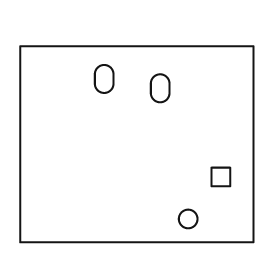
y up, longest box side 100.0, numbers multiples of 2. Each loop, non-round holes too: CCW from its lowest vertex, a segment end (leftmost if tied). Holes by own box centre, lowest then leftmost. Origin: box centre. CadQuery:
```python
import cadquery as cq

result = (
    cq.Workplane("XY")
    .moveTo(-50.0, -42.0)
    .lineTo(50.0, -42.0)
    .lineTo(50.0, 42.0)
    .lineTo(-50.0, 42.0)
    .close()
    .moveTo(22.0, -32.0)
    .circle(4.0)
    .moveTo(32.0, -18.0)
    .lineTo(40.0, -18.0)
    .lineTo(40.0, -10.0)
    .lineTo(32.0, -10.0)
    .close()
    .moveTo(6.0, 22.0)
    .threePointArc((10.0, 18.0), (14.0, 22.0))
    .lineTo(14.0, 26.0)
    .threePointArc((10.0, 30.0), (6.0, 26.0))
    .close()
    .moveTo(-18.0, 26.0)
    .threePointArc((-14.0, 22.0), (-10.0, 26.0))
    .lineTo(-10.0, 30.0)
    .threePointArc((-14.0, 34.0), (-18.0, 30.0))
    .close()
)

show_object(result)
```